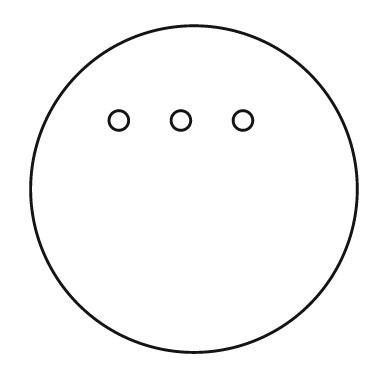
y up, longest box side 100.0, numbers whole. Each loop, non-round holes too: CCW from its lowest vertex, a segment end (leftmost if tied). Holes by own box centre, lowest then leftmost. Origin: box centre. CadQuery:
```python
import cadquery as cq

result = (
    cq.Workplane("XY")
    .moveTo(0.0, 0.0)
    .circle(50.0)
    .moveTo(-23.0, 21.0)
    .circle(3.0)
    .moveTo(-4.0, 21.0)
    .circle(3.0)
    .moveTo(15.0, 21.0)
    .circle(3.0)
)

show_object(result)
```